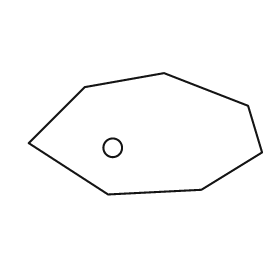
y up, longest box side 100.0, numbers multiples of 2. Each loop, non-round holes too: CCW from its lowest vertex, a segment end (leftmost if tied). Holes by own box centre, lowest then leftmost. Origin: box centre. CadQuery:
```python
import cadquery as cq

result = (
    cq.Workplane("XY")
    .moveTo(-16.0, -26.0)
    .lineTo(24.0, -24.0)
    .lineTo(50.0, -8.0)
    .lineTo(44.0, 12.0)
    .lineTo(8.0, 26.0)
    .lineTo(-26.0, 20.0)
    .lineTo(-50.0, -4.0)
    .close()
    .moveTo(-14.0, -6.0)
    .circle(4.0)
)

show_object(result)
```